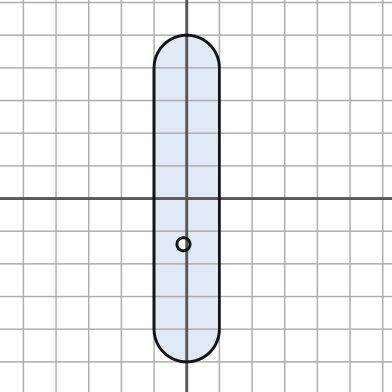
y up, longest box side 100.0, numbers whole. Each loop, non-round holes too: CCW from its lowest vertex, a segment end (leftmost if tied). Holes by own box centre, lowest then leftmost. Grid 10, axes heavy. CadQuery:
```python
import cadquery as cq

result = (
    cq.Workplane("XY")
    .moveTo(-10.0, -40.0)
    .threePointArc((0.0, -50.0), (10.0, -40.0))
    .lineTo(10.0, 40.0)
    .threePointArc((0.0, 50.0), (-10.0, 40.0))
    .close()
    .moveTo(-1.0, -14.0)
    .circle(2.0)
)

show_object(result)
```